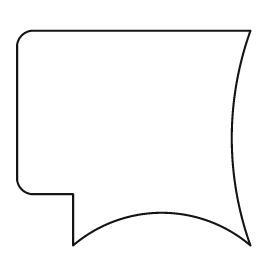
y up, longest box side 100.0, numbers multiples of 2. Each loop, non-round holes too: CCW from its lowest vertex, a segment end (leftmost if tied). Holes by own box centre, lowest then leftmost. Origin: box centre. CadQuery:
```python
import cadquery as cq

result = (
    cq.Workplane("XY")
    .moveTo(-26.0, -46.0)
    .threePointArc((12.0, -32.0), (50.0, -46.0))
    .threePointArc((42.0, 0.0), (50.0, 46.0))
    .lineTo(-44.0, 46.0)
    .threePointArc((-48.0, 44.0), (-50.0, 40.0))
    .lineTo(-50.0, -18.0)
    .threePointArc((-48.0, -22.0), (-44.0, -24.0))
    .lineTo(-26.0, -24.0)
    .close()
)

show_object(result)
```